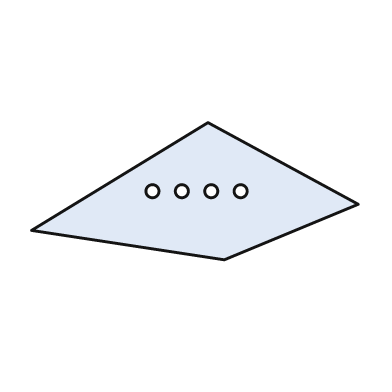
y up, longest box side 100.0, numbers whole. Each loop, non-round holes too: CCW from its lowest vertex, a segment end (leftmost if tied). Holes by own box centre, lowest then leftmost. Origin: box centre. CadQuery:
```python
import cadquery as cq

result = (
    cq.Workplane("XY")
    .moveTo(9.0, -21.0)
    .lineTo(50.0, -4.0)
    .lineTo(4.0, 21.0)
    .lineTo(-50.0, -12.0)
    .close()
    .moveTo(-13.0, 0.0)
    .circle(2.0)
    .moveTo(-4.0, 0.0)
    .circle(2.0)
    .moveTo(5.0, 0.0)
    .circle(2.0)
    .moveTo(14.0, 0.0)
    .circle(2.0)
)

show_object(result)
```